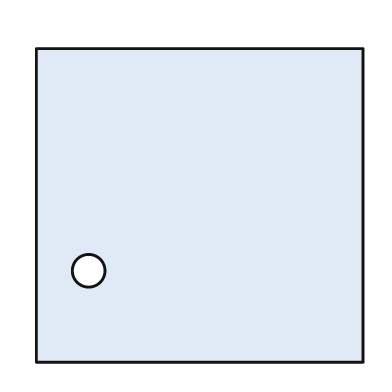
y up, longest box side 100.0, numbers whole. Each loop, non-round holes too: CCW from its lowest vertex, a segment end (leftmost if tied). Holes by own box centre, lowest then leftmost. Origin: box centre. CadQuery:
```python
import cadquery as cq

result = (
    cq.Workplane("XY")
    .moveTo(-50.0, -48.0)
    .lineTo(50.0, -48.0)
    .lineTo(50.0, 48.0)
    .lineTo(-50.0, 48.0)
    .close()
    .moveTo(-34.0, -20.0)
    .circle(5.0)
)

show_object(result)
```